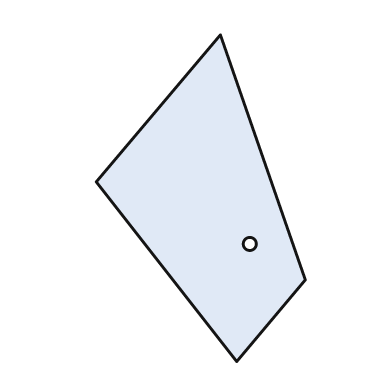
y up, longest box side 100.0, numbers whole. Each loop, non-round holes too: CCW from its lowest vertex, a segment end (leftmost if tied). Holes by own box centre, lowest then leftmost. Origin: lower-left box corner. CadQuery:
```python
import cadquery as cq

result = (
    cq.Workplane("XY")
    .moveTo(43.0, 0.0)
    .lineTo(64.0, 25.0)
    .lineTo(38.0, 100.0)
    .lineTo(0.0, 55.0)
    .close()
    .moveTo(47.0, 36.0)
    .circle(2.0)
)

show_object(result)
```